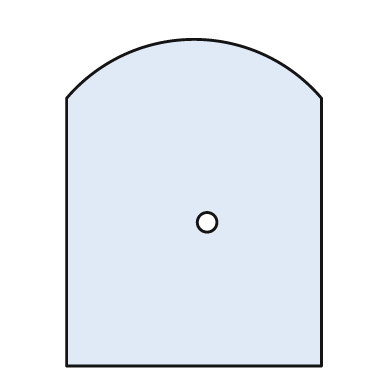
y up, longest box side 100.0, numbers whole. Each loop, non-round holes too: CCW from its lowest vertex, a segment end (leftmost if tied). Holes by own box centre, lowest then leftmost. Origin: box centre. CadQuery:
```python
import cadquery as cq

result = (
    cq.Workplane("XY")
    .moveTo(-39.0, -50.0)
    .lineTo(39.0, -50.0)
    .lineTo(39.0, 32.0)
    .threePointArc((0.0, 50.0), (-39.0, 32.0))
    .close()
    .moveTo(4.0, -6.0)
    .circle(3.0)
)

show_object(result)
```